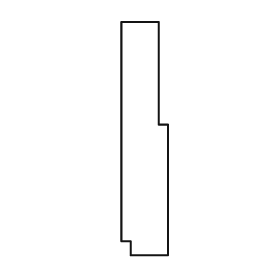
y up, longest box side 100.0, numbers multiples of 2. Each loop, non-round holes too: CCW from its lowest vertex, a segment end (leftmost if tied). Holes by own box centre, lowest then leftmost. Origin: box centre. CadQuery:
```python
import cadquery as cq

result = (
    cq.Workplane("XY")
    .moveTo(-6.0, -50.0)
    .lineTo(10.0, -50.0)
    .lineTo(10.0, 6.0)
    .lineTo(6.0, 6.0)
    .lineTo(6.0, 50.0)
    .lineTo(-10.0, 50.0)
    .lineTo(-10.0, -44.0)
    .lineTo(-6.0, -44.0)
    .close()
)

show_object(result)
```